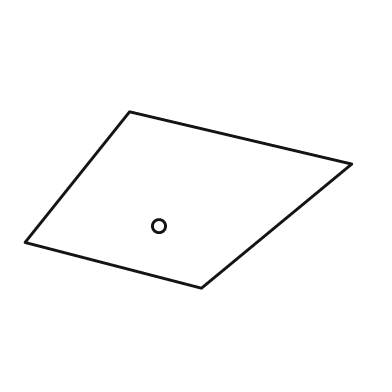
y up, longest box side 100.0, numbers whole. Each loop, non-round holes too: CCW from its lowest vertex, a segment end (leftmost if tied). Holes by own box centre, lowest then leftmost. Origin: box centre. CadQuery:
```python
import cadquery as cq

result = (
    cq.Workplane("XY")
    .moveTo(4.0, -27.0)
    .lineTo(50.0, 11.0)
    .lineTo(-18.0, 27.0)
    .lineTo(-50.0, -13.0)
    .close()
    .moveTo(-9.0, -8.0)
    .circle(2.0)
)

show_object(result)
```